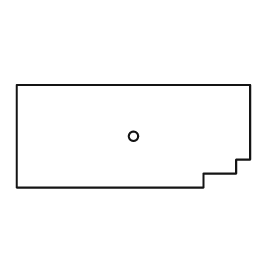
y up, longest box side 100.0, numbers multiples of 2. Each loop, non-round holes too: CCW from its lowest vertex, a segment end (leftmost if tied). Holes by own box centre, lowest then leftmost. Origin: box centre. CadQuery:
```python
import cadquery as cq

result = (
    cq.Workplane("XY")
    .moveTo(-50.0, -22.0)
    .lineTo(30.0, -22.0)
    .lineTo(30.0, -16.0)
    .lineTo(44.0, -16.0)
    .lineTo(44.0, -10.0)
    .lineTo(50.0, -10.0)
    .lineTo(50.0, 22.0)
    .lineTo(-50.0, 22.0)
    .close()
    .moveTo(0.0, 0.0)
    .circle(2.0)
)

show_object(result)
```